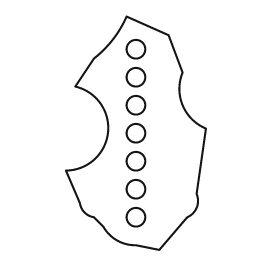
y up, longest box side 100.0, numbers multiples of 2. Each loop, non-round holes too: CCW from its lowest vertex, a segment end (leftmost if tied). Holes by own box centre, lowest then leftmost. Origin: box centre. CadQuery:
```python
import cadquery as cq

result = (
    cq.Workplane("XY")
    .moveTo(10.0, -50.0)
    .lineTo(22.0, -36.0)
    .threePointArc((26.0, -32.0), (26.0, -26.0))
    .lineTo(30.0, 2.0)
    .threePointArc((20.0, 12.0), (20.0, 26.0))
    .lineTo(14.0, 42.0)
    .lineTo(-4.0, 50.0)
    .threePointArc((-10.0, 40.0), (-18.0, 32.0))
    .lineTo(-26.0, 20.0)
    .threePointArc((-12.0, 0.0), (-30.0, -16.0))
    .lineTo(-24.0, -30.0)
    .threePointArc((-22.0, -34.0), (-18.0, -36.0))
    .lineTo(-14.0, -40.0)
    .threePointArc((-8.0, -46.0), (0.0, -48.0))
    .close()
    .moveTo(0.0, -36.0)
    .circle(4.0)
    .moveTo(0.0, -24.0)
    .circle(4.0)
    .moveTo(0.0, -12.0)
    .circle(4.0)
    .moveTo(0.0, 0.0)
    .circle(4.0)
    .moveTo(0.0, 12.0)
    .circle(4.0)
    .moveTo(0.0, 24.0)
    .circle(4.0)
    .moveTo(0.0, 36.0)
    .circle(4.0)
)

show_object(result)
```